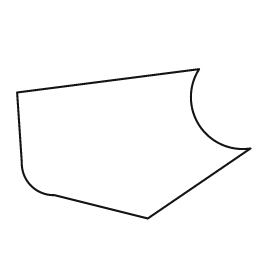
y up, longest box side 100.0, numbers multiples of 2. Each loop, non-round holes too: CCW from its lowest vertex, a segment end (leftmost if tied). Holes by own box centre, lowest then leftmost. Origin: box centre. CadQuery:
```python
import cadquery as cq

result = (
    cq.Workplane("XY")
    .moveTo(6.0, -32.0)
    .lineTo(50.0, -2.0)
    .threePointArc((28.0, 8.0), (28.0, 32.0))
    .lineTo(-50.0, 22.0)
    .lineTo(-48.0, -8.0)
    .threePointArc((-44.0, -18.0), (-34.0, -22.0))
    .close()
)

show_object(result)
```